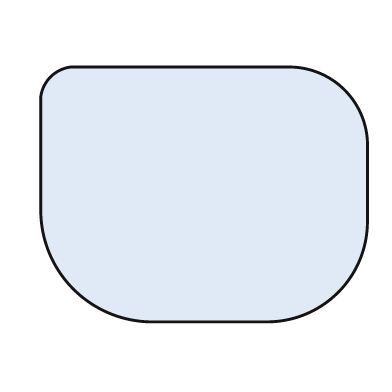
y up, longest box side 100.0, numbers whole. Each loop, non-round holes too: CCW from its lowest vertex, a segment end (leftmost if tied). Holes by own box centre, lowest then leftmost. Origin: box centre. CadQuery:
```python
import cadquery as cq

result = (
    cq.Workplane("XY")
    .moveTo(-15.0, -39.0)
    .lineTo(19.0, -39.0)
    .threePointArc((41.0, -30.0), (50.0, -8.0))
    .lineTo(50.0, 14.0)
    .threePointArc((43.0, 32.0), (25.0, 39.0))
    .lineTo(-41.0, 39.0)
    .threePointArc((-47.0, 36.0), (-50.0, 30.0))
    .lineTo(-50.0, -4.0)
    .threePointArc((-40.0, -29.0), (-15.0, -39.0))
    .close()
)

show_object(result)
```